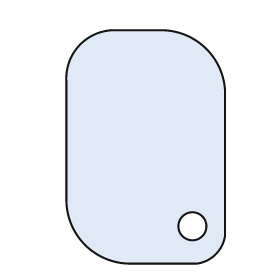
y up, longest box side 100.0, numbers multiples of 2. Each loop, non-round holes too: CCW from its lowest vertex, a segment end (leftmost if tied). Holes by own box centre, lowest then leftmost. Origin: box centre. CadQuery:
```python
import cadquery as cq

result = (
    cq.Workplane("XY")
    .moveTo(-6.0, -50.0)
    .lineTo(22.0, -50.0)
    .threePointArc((30.0, -46.0), (34.0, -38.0))
    .lineTo(34.0, 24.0)
    .threePointArc((26.0, 42.0), (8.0, 50.0))
    .lineTo(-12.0, 50.0)
    .threePointArc((-28.0, 44.0), (-34.0, 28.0))
    .lineTo(-34.0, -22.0)
    .threePointArc((-26.0, -42.0), (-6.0, -50.0))
    .close()
    .moveTo(20.0, -34.0)
    .circle(6.0)
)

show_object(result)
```